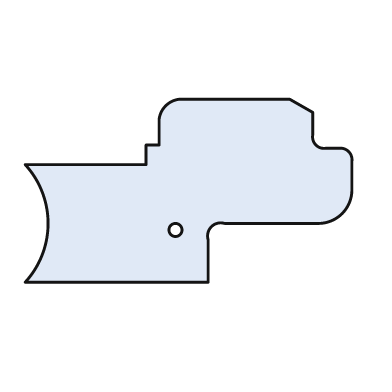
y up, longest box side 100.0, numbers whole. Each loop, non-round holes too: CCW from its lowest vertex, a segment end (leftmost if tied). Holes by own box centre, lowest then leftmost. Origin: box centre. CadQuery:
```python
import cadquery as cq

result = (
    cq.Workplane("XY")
    .moveTo(-50.0, -28.0)
    .lineTo(6.0, -28.0)
    .lineTo(6.0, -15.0)
    .threePointArc((7.0, -11.0), (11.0, -10.0))
    .lineTo(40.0, -10.0)
    .threePointArc((47.0, -7.0), (50.0, 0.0))
    .lineTo(50.0, 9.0)
    .threePointArc((49.0, 12.0), (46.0, 13.0))
    .lineTo(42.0, 13.0)
    .threePointArc((39.0, 14.0), (38.0, 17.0))
    .lineTo(38.0, 24.0)
    .lineTo(31.0, 28.0)
    .lineTo(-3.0, 28.0)
    .threePointArc((-7.0, 26.0), (-9.0, 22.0))
    .lineTo(-9.0, 14.0)
    .lineTo(-13.0, 14.0)
    .lineTo(-13.0, 8.0)
    .lineTo(-50.0, 8.0)
    .threePointArc((-43.0, -10.0), (-50.0, -28.0))
    .close()
    .moveTo(-4.0, -12.0)
    .circle(2.0)
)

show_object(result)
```